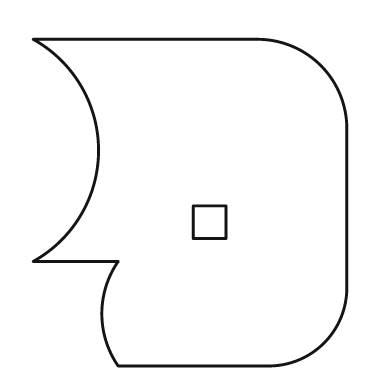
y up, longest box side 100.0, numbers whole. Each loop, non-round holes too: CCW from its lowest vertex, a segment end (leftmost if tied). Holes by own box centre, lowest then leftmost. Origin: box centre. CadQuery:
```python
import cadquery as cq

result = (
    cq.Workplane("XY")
    .moveTo(-22.0, -50.0)
    .lineTo(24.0, -50.0)
    .threePointArc((41.0, -43.0), (48.0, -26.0))
    .lineTo(48.0, 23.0)
    .threePointArc((40.0, 42.0), (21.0, 50.0))
    .lineTo(-48.0, 50.0)
    .threePointArc((-28.0, 16.0), (-48.0, -18.0))
    .lineTo(-22.0, -18.0)
    .threePointArc((-27.0, -34.0), (-22.0, -50.0))
    .close()
    .moveTo(1.0, -11.0)
    .lineTo(11.0, -11.0)
    .lineTo(11.0, -1.0)
    .lineTo(1.0, -1.0)
    .close()
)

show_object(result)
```